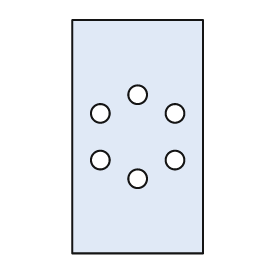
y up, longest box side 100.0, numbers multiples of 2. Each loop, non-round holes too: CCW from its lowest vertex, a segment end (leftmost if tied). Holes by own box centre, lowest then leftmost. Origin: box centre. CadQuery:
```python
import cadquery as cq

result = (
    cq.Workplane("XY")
    .moveTo(-28.0, -50.0)
    .lineTo(28.0, -50.0)
    .lineTo(28.0, 50.0)
    .lineTo(-28.0, 50.0)
    .close()
    .moveTo(0.0, -18.0)
    .circle(4.0)
    .moveTo(-16.0, -10.0)
    .circle(4.0)
    .moveTo(16.0, -10.0)
    .circle(4.0)
    .moveTo(-16.0, 10.0)
    .circle(4.0)
    .moveTo(16.0, 10.0)
    .circle(4.0)
    .moveTo(0.0, 18.0)
    .circle(4.0)
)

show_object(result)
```